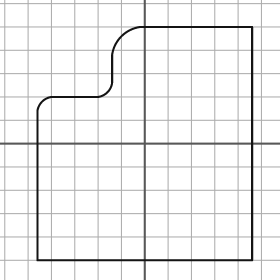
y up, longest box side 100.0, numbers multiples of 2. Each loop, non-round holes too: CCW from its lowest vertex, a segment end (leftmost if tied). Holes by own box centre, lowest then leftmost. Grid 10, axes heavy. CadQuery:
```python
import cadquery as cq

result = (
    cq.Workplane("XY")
    .moveTo(-46.0, -50.0)
    .lineTo(46.0, -50.0)
    .lineTo(46.0, 50.0)
    .lineTo(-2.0, 50.0)
    .threePointArc((-10.0, 46.0), (-14.0, 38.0))
    .lineTo(-14.0, 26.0)
    .threePointArc((-16.0, 22.0), (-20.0, 20.0))
    .lineTo(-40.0, 20.0)
    .threePointArc((-44.0, 18.0), (-46.0, 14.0))
    .close()
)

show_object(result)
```